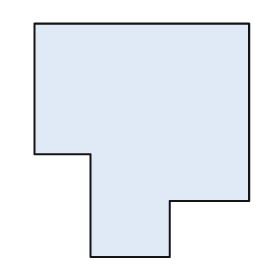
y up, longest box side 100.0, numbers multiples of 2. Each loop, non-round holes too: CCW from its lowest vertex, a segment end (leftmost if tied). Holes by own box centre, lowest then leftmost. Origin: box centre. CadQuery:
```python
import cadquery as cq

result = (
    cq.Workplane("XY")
    .moveTo(-22.0, -50.0)
    .lineTo(12.0, -50.0)
    .lineTo(12.0, -26.0)
    .lineTo(46.0, -26.0)
    .lineTo(46.0, 50.0)
    .lineTo(-46.0, 50.0)
    .lineTo(-46.0, -6.0)
    .lineTo(-22.0, -6.0)
    .close()
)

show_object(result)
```